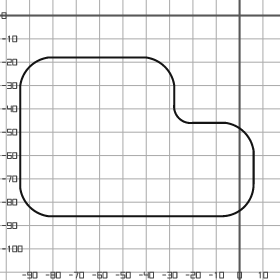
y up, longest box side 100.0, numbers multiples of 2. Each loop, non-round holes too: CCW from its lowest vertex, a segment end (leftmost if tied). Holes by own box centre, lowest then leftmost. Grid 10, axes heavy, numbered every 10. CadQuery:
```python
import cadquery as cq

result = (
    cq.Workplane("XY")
    .moveTo(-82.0, -86.0)
    .lineTo(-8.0, -86.0)
    .threePointArc((2.0, -82.0), (6.0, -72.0))
    .lineTo(6.0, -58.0)
    .threePointArc((2.0, -50.0), (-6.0, -46.0))
    .lineTo(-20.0, -46.0)
    .threePointArc((-26.0, -44.0), (-28.0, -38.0))
    .lineTo(-28.0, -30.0)
    .threePointArc((-32.0, -22.0), (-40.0, -18.0))
    .lineTo(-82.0, -18.0)
    .threePointArc((-90.0, -22.0), (-94.0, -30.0))
    .lineTo(-94.0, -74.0)
    .threePointArc((-90.0, -82.0), (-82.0, -86.0))
    .close()
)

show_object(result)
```